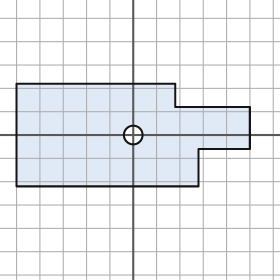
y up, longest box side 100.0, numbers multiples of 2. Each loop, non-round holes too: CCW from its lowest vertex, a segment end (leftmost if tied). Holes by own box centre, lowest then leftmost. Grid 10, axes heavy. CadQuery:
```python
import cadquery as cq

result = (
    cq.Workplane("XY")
    .moveTo(-50.0, -22.0)
    .lineTo(28.0, -22.0)
    .lineTo(28.0, -6.0)
    .lineTo(50.0, -6.0)
    .lineTo(50.0, 12.0)
    .lineTo(18.0, 12.0)
    .lineTo(18.0, 22.0)
    .lineTo(-50.0, 22.0)
    .close()
    .moveTo(0.0, 0.0)
    .circle(4.0)
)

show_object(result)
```